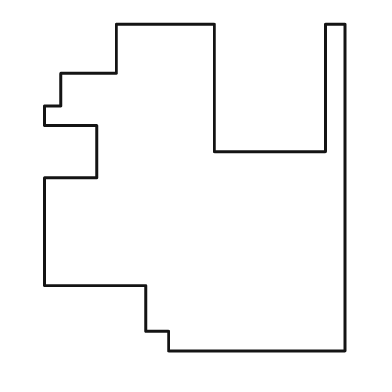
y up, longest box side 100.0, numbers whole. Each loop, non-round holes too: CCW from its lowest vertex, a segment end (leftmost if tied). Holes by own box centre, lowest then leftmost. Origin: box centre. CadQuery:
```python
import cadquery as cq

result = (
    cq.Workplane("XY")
    .moveTo(-8.0, -50.0)
    .lineTo(46.0, -50.0)
    .lineTo(46.0, 50.0)
    .lineTo(40.0, 50.0)
    .lineTo(40.0, 11.0)
    .lineTo(6.0, 11.0)
    .lineTo(6.0, 50.0)
    .lineTo(-24.0, 50.0)
    .lineTo(-24.0, 35.0)
    .lineTo(-41.0, 35.0)
    .lineTo(-41.0, 25.0)
    .lineTo(-46.0, 25.0)
    .lineTo(-46.0, 19.0)
    .lineTo(-30.0, 19.0)
    .lineTo(-30.0, 3.0)
    .lineTo(-46.0, 3.0)
    .lineTo(-46.0, -30.0)
    .lineTo(-15.0, -30.0)
    .lineTo(-15.0, -44.0)
    .lineTo(-8.0, -44.0)
    .close()
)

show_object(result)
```